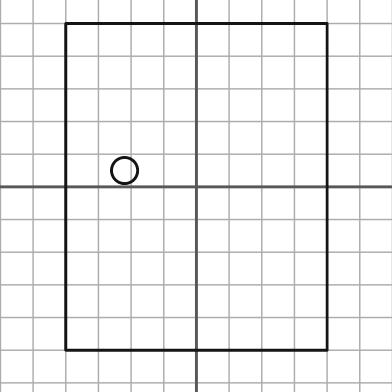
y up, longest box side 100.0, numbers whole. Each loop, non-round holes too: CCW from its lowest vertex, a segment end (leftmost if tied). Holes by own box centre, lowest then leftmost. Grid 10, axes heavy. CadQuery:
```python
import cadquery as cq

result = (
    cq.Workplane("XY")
    .moveTo(-40.0, -50.0)
    .lineTo(40.0, -50.0)
    .lineTo(40.0, 50.0)
    .lineTo(-40.0, 50.0)
    .close()
    .moveTo(-22.0, 5.0)
    .circle(4.0)
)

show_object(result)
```